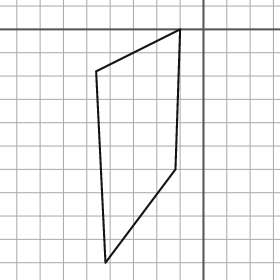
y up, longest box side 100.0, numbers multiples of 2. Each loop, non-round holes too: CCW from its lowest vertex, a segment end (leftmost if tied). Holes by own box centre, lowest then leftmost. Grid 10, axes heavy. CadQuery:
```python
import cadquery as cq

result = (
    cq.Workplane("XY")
    .moveTo(-42.0, -100.0)
    .lineTo(-12.0, -60.0)
    .lineTo(-10.0, 0.0)
    .lineTo(-46.0, -18.0)
    .close()
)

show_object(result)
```